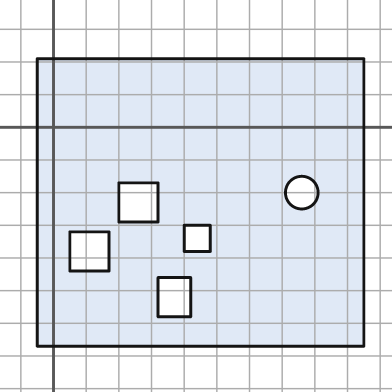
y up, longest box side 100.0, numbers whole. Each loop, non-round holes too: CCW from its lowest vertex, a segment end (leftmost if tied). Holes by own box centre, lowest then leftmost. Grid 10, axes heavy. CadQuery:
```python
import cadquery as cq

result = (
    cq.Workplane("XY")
    .moveTo(-5.0, -67.0)
    .lineTo(95.0, -67.0)
    .lineTo(95.0, 21.0)
    .lineTo(-5.0, 21.0)
    .close()
    .moveTo(32.0, -58.0)
    .lineTo(42.0, -58.0)
    .lineTo(42.0, -46.0)
    .lineTo(32.0, -46.0)
    .close()
    .moveTo(5.0, -44.0)
    .lineTo(17.0, -44.0)
    .lineTo(17.0, -32.0)
    .lineTo(5.0, -32.0)
    .close()
    .moveTo(40.0, -38.0)
    .lineTo(48.0, -38.0)
    .lineTo(48.0, -30.0)
    .lineTo(40.0, -30.0)
    .close()
    .moveTo(20.0, -29.0)
    .lineTo(32.0, -29.0)
    .lineTo(32.0, -17.0)
    .lineTo(20.0, -17.0)
    .close()
    .moveTo(76.0, -20.0)
    .circle(5.0)
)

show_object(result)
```